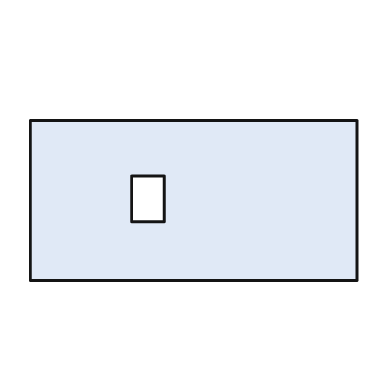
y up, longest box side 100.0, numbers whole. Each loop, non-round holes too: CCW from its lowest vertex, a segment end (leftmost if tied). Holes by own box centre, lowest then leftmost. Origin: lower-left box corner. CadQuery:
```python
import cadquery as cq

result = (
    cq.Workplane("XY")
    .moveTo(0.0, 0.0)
    .lineTo(100.0, 0.0)
    .lineTo(100.0, 49.0)
    .lineTo(0.0, 49.0)
    .close()
    .moveTo(31.0, 18.0)
    .lineTo(41.0, 18.0)
    .lineTo(41.0, 32.0)
    .lineTo(31.0, 32.0)
    .close()
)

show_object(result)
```